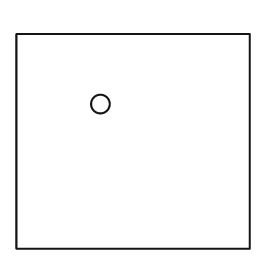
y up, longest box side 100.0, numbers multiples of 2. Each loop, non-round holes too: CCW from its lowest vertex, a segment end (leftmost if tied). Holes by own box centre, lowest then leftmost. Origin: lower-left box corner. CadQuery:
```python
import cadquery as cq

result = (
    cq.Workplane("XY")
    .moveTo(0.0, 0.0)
    .lineTo(100.0, 0.0)
    .lineTo(100.0, 92.0)
    .lineTo(0.0, 92.0)
    .close()
    .moveTo(36.0, 62.0)
    .circle(4.0)
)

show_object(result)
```